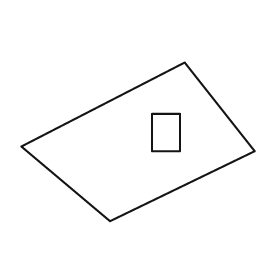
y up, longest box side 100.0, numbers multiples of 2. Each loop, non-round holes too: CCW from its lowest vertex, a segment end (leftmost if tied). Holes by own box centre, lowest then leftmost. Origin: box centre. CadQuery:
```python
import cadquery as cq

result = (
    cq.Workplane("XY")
    .moveTo(-12.0, -34.0)
    .lineTo(50.0, -4.0)
    .lineTo(20.0, 34.0)
    .lineTo(-50.0, -2.0)
    .close()
    .moveTo(6.0, -4.0)
    .lineTo(18.0, -4.0)
    .lineTo(18.0, 12.0)
    .lineTo(6.0, 12.0)
    .close()
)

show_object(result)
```